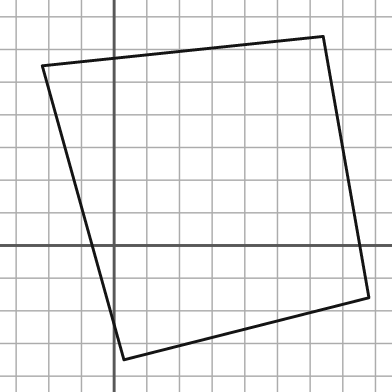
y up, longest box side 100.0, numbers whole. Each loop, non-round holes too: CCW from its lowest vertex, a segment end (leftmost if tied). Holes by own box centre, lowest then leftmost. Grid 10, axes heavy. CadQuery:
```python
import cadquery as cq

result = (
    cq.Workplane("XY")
    .moveTo(3.0, -35.0)
    .lineTo(78.0, -16.0)
    .lineTo(64.0, 64.0)
    .lineTo(-22.0, 55.0)
    .close()
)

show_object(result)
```